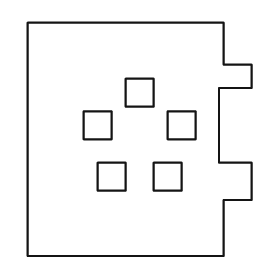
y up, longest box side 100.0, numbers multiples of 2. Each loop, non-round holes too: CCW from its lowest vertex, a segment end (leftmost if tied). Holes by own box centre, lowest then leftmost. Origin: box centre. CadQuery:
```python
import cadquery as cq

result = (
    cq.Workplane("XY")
    .moveTo(-48.0, -50.0)
    .lineTo(36.0, -50.0)
    .lineTo(36.0, -26.0)
    .lineTo(48.0, -26.0)
    .lineTo(48.0, -10.0)
    .lineTo(34.0, -10.0)
    .lineTo(34.0, 22.0)
    .lineTo(48.0, 22.0)
    .lineTo(48.0, 32.0)
    .lineTo(36.0, 32.0)
    .lineTo(36.0, 50.0)
    .lineTo(-48.0, 50.0)
    .close()
    .moveTo(-18.0, -22.0)
    .lineTo(-6.0, -22.0)
    .lineTo(-6.0, -10.0)
    .lineTo(-18.0, -10.0)
    .close()
    .moveTo(6.0, -22.0)
    .lineTo(18.0, -22.0)
    .lineTo(18.0, -10.0)
    .lineTo(6.0, -10.0)
    .close()
    .moveTo(-24.0, 0.0)
    .lineTo(-12.0, 0.0)
    .lineTo(-12.0, 12.0)
    .lineTo(-24.0, 12.0)
    .close()
    .moveTo(12.0, 0.0)
    .lineTo(24.0, 0.0)
    .lineTo(24.0, 12.0)
    .lineTo(12.0, 12.0)
    .close()
    .moveTo(-6.0, 14.0)
    .lineTo(6.0, 14.0)
    .lineTo(6.0, 26.0)
    .lineTo(-6.0, 26.0)
    .close()
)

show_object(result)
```